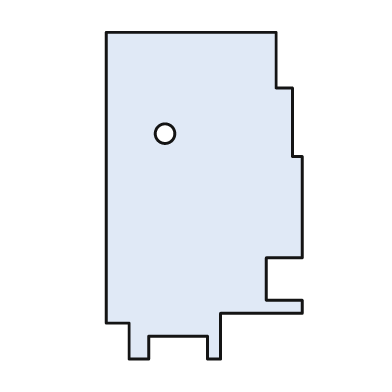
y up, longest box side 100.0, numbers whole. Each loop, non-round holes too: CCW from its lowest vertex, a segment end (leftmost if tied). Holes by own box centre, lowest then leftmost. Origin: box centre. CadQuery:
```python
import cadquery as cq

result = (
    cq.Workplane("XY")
    .moveTo(-23.0, -50.0)
    .lineTo(-17.0, -50.0)
    .lineTo(-17.0, -43.0)
    .lineTo(1.0, -43.0)
    .lineTo(1.0, -50.0)
    .lineTo(5.0, -50.0)
    .lineTo(5.0, -36.0)
    .lineTo(30.0, -36.0)
    .lineTo(30.0, -32.0)
    .lineTo(19.0, -32.0)
    .lineTo(19.0, -19.0)
    .lineTo(30.0, -19.0)
    .lineTo(30.0, 12.0)
    .lineTo(27.0, 12.0)
    .lineTo(27.0, 33.0)
    .lineTo(22.0, 33.0)
    .lineTo(22.0, 50.0)
    .lineTo(-30.0, 50.0)
    .lineTo(-30.0, -39.0)
    .lineTo(-23.0, -39.0)
    .close()
    .moveTo(-12.0, 19.0)
    .circle(3.0)
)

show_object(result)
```